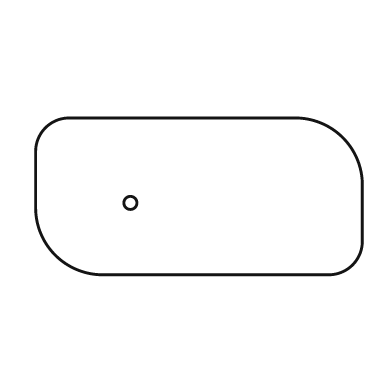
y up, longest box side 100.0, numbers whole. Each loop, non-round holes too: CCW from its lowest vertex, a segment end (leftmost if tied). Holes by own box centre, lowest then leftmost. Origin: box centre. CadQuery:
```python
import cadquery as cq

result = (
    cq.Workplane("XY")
    .moveTo(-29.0, -24.0)
    .lineTo(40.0, -24.0)
    .threePointArc((47.0, -21.0), (50.0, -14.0))
    .lineTo(50.0, 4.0)
    .threePointArc((44.0, 18.0), (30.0, 24.0))
    .lineTo(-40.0, 24.0)
    .threePointArc((-47.0, 21.0), (-50.0, 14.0))
    .lineTo(-50.0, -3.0)
    .threePointArc((-44.0, -18.0), (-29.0, -24.0))
    .close()
    .moveTo(-21.0, -2.0)
    .circle(2.0)
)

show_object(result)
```